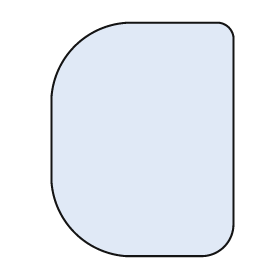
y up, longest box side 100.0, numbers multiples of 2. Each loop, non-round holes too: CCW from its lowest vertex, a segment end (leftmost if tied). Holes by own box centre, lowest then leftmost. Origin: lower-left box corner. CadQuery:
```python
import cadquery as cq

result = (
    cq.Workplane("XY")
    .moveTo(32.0, 0.0)
    .lineTo(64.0, 0.0)
    .threePointArc((74.0, 4.0), (78.0, 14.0))
    .lineTo(78.0, 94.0)
    .threePointArc((76.0, 98.0), (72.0, 100.0))
    .lineTo(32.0, 100.0)
    .threePointArc((10.0, 90.0), (0.0, 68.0))
    .lineTo(0.0, 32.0)
    .threePointArc((10.0, 10.0), (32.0, 0.0))
    .close()
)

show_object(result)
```